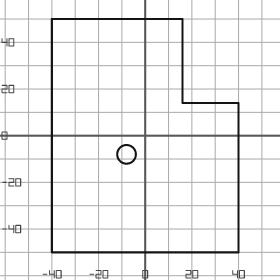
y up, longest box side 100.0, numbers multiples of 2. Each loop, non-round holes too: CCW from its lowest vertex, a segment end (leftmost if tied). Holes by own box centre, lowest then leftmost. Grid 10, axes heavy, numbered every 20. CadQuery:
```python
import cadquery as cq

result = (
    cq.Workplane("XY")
    .moveTo(-40.0, -50.0)
    .lineTo(40.0, -50.0)
    .lineTo(40.0, 14.0)
    .lineTo(16.0, 14.0)
    .lineTo(16.0, 50.0)
    .lineTo(-40.0, 50.0)
    .close()
    .moveTo(-8.0, -8.0)
    .circle(4.0)
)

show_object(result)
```